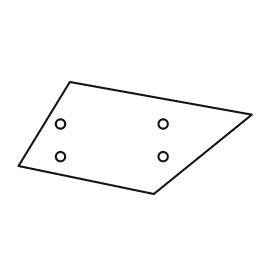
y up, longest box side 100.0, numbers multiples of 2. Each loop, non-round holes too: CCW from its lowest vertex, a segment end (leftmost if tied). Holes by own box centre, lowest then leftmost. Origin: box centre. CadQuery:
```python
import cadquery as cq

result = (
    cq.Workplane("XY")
    .moveTo(8.0, -24.0)
    .lineTo(50.0, 10.0)
    .lineTo(-28.0, 24.0)
    .lineTo(-50.0, -12.0)
    .close()
    .moveTo(-32.0, -8.0)
    .circle(2.0)
    .moveTo(12.0, -8.0)
    .circle(2.0)
    .moveTo(-32.0, 6.0)
    .circle(2.0)
    .moveTo(12.0, 6.0)
    .circle(2.0)
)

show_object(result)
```